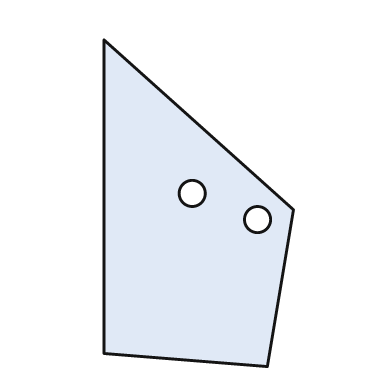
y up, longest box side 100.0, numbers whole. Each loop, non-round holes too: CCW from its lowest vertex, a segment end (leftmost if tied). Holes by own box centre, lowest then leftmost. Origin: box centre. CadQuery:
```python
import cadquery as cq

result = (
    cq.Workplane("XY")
    .moveTo(21.0, -50.0)
    .lineTo(29.0, -2.0)
    .lineTo(-29.0, 50.0)
    .lineTo(-29.0, -46.0)
    .close()
    .moveTo(18.0, -5.0)
    .circle(4.0)
    .moveTo(-2.0, 3.0)
    .circle(4.0)
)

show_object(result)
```